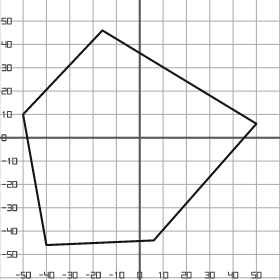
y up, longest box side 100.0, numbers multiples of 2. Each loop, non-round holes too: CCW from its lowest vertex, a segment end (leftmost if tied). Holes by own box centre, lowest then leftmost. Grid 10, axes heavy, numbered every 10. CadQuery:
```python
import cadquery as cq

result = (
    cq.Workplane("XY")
    .moveTo(-40.0, -46.0)
    .lineTo(6.0, -44.0)
    .lineTo(50.0, 6.0)
    .lineTo(-16.0, 46.0)
    .lineTo(-50.0, 10.0)
    .close()
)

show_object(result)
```